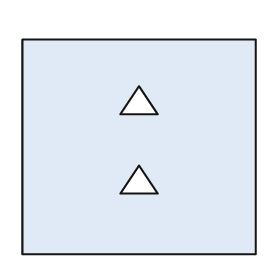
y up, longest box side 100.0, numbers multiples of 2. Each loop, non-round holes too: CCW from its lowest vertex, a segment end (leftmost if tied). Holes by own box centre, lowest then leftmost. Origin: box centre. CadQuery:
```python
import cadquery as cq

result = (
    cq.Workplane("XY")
    .moveTo(-50.0, -46.0)
    .lineTo(50.0, -46.0)
    .lineTo(50.0, 46.0)
    .lineTo(-50.0, 46.0)
    .close()
    .moveTo(-8.0, -20.0)
    .lineTo(8.0, -20.0)
    .lineTo(0.0, -8.0)
    .close()
    .moveTo(-8.0, 14.0)
    .lineTo(8.0, 14.0)
    .lineTo(0.0, 26.0)
    .close()
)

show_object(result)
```